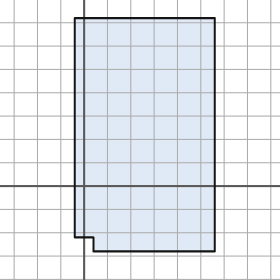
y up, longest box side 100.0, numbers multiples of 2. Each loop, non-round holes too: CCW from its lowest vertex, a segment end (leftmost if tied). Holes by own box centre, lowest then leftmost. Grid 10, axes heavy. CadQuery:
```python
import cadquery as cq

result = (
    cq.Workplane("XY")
    .moveTo(4.0, -28.0)
    .lineTo(56.0, -28.0)
    .lineTo(56.0, 72.0)
    .lineTo(-4.0, 72.0)
    .lineTo(-4.0, -22.0)
    .lineTo(4.0, -22.0)
    .close()
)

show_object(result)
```